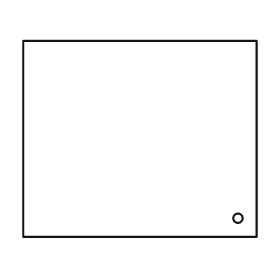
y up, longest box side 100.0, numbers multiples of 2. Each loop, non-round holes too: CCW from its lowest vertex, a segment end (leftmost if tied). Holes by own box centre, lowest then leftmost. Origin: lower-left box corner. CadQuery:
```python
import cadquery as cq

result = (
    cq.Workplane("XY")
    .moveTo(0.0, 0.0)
    .lineTo(100.0, 0.0)
    .lineTo(100.0, 84.0)
    .lineTo(0.0, 84.0)
    .close()
    .moveTo(92.0, 8.0)
    .circle(2.0)
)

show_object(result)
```